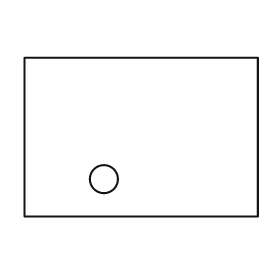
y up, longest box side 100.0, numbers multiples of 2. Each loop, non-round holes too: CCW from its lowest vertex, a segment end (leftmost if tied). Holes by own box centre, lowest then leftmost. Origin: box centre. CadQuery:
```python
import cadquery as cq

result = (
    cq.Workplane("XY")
    .moveTo(-50.0, -34.0)
    .lineTo(50.0, -34.0)
    .lineTo(50.0, 34.0)
    .lineTo(-50.0, 34.0)
    .close()
    .moveTo(-16.0, -18.0)
    .circle(6.0)
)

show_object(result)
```